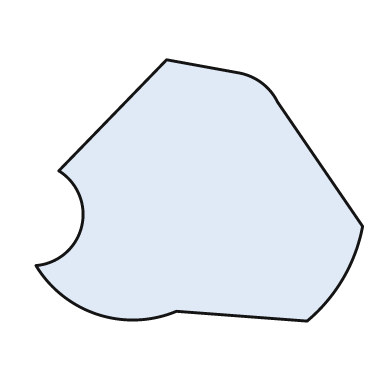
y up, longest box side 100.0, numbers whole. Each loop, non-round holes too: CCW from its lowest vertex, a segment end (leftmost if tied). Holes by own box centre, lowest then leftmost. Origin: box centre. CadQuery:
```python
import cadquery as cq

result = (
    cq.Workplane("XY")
    .moveTo(33.0, -40.0)
    .threePointArc((44.0, -27.0), (50.0, -11.0))
    .lineTo(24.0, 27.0)
    .threePointArc((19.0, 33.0), (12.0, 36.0))
    .lineTo(-10.0, 40.0)
    .lineTo(-43.0, 6.0)
    .threePointArc((-36.0, -11.0), (-50.0, -23.0))
    .threePointArc((-31.0, -38.0), (-7.0, -37.0))
    .close()
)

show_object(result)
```